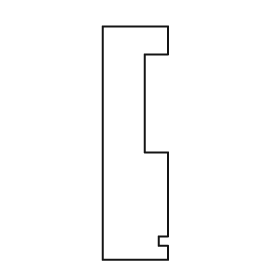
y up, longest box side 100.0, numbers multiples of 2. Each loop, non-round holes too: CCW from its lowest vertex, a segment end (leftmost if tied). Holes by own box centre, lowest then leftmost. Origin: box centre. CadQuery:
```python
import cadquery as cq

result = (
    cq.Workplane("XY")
    .moveTo(-14.0, -50.0)
    .lineTo(14.0, -50.0)
    .lineTo(14.0, -44.0)
    .lineTo(10.0, -44.0)
    .lineTo(10.0, -40.0)
    .lineTo(14.0, -40.0)
    .lineTo(14.0, -4.0)
    .lineTo(4.0, -4.0)
    .lineTo(4.0, 38.0)
    .lineTo(14.0, 38.0)
    .lineTo(14.0, 50.0)
    .lineTo(-14.0, 50.0)
    .close()
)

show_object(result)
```